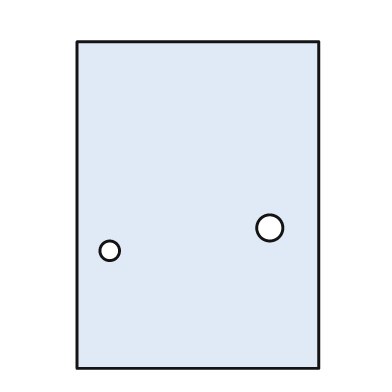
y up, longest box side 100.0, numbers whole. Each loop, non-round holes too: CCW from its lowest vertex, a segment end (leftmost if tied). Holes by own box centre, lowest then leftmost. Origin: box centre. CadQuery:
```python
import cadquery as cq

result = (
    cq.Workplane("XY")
    .moveTo(-37.0, -50.0)
    .lineTo(37.0, -50.0)
    .lineTo(37.0, 50.0)
    .lineTo(-37.0, 50.0)
    .close()
    .moveTo(-27.0, -14.0)
    .circle(3.0)
    .moveTo(22.0, -7.0)
    .circle(4.0)
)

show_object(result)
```